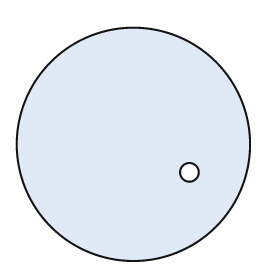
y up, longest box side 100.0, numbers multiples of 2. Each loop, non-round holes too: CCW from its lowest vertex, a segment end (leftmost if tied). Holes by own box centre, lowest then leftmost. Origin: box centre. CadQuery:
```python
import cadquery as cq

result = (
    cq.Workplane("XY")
    .moveTo(0.0, 0.0)
    .circle(50.0)
    .moveTo(24.0, -12.0)
    .circle(4.0)
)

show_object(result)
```